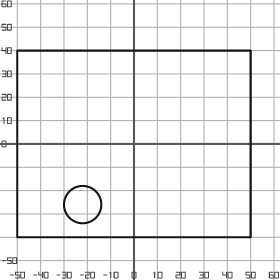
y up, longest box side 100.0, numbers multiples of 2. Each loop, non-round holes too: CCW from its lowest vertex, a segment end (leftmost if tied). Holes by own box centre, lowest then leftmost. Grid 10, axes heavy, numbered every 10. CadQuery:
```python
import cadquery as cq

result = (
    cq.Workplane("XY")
    .moveTo(-50.0, -40.0)
    .lineTo(50.0, -40.0)
    .lineTo(50.0, 40.0)
    .lineTo(-50.0, 40.0)
    .close()
    .moveTo(-22.0, -26.0)
    .circle(8.0)
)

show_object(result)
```